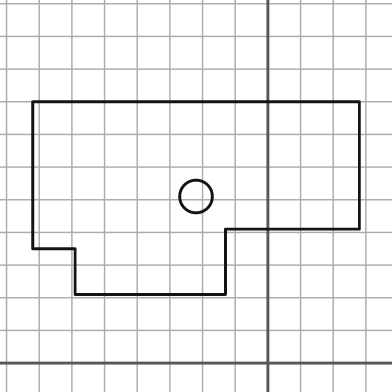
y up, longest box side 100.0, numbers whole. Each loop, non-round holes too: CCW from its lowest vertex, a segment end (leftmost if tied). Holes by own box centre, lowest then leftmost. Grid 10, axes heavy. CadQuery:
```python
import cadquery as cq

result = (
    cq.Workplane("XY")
    .moveTo(-59.0, 21.0)
    .lineTo(-13.0, 21.0)
    .lineTo(-13.0, 41.0)
    .lineTo(28.0, 41.0)
    .lineTo(28.0, 80.0)
    .lineTo(-72.0, 80.0)
    .lineTo(-72.0, 35.0)
    .lineTo(-59.0, 35.0)
    .close()
    .moveTo(-22.0, 51.0)
    .circle(5.0)
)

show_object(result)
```